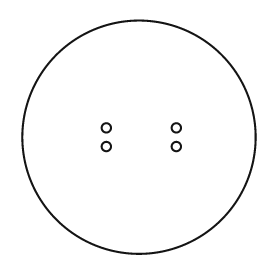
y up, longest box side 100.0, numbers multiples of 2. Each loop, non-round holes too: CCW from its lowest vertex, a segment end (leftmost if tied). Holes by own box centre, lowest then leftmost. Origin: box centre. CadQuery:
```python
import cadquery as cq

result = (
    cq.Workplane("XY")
    .moveTo(0.0, 0.0)
    .circle(50.0)
    .moveTo(-14.0, -4.0)
    .circle(2.0)
    .moveTo(16.0, -4.0)
    .circle(2.0)
    .moveTo(-14.0, 4.0)
    .circle(2.0)
    .moveTo(16.0, 4.0)
    .circle(2.0)
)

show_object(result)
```